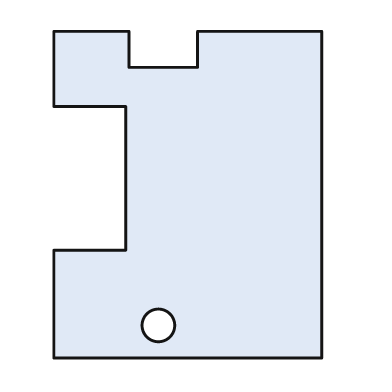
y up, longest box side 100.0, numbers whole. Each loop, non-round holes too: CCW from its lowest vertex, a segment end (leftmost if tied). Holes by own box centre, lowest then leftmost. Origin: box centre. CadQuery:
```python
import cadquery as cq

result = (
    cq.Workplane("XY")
    .moveTo(-41.0, -50.0)
    .lineTo(41.0, -50.0)
    .lineTo(41.0, 50.0)
    .lineTo(3.0, 50.0)
    .lineTo(3.0, 39.0)
    .lineTo(-18.0, 39.0)
    .lineTo(-18.0, 50.0)
    .lineTo(-41.0, 50.0)
    .lineTo(-41.0, 27.0)
    .lineTo(-19.0, 27.0)
    .lineTo(-19.0, -17.0)
    .lineTo(-41.0, -17.0)
    .close()
    .moveTo(-9.0, -40.0)
    .circle(5.0)
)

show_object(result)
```